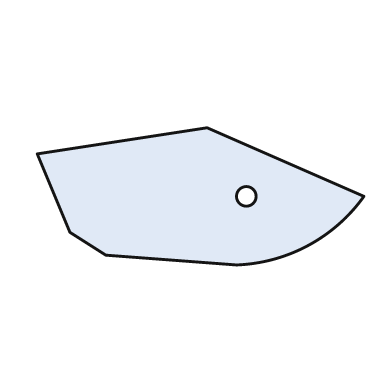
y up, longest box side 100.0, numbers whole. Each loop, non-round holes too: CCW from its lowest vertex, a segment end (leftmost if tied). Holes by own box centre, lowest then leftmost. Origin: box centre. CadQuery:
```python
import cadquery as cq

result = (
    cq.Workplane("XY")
    .moveTo(11.0, -21.0)
    .threePointArc((33.0, -15.0), (50.0, 0.0))
    .lineTo(2.0, 21.0)
    .lineTo(-50.0, 13.0)
    .lineTo(-40.0, -11.0)
    .lineTo(-29.0, -18.0)
    .close()
    .moveTo(14.0, 0.0)
    .circle(3.0)
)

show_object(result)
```